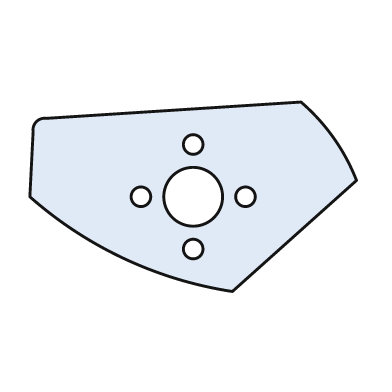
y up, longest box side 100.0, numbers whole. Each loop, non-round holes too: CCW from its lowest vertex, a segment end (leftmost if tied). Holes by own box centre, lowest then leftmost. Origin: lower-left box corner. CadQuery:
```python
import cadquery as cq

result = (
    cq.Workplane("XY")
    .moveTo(62.0, 0.0)
    .lineTo(100.0, 34.0)
    .threePointArc((93.0, 47.0), (83.0, 58.0))
    .lineTo(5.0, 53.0)
    .threePointArc((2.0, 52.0), (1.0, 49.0))
    .lineTo(0.0, 29.0)
    .threePointArc((29.0, 10.0), (62.0, 0.0))
    .close()
    .moveTo(50.0, 13.0)
    .circle(3.0)
    .moveTo(34.0, 29.0)
    .circle(3.0)
    .moveTo(50.0, 29.0)
    .circle(9.0)
    .moveTo(66.0, 29.0)
    .circle(3.0)
    .moveTo(50.0, 45.0)
    .circle(3.0)
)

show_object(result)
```